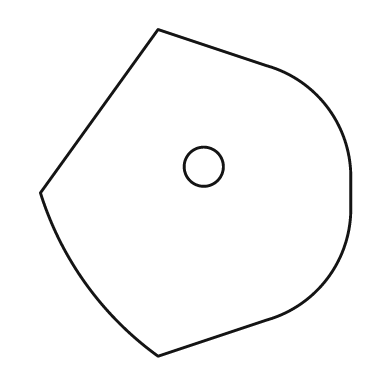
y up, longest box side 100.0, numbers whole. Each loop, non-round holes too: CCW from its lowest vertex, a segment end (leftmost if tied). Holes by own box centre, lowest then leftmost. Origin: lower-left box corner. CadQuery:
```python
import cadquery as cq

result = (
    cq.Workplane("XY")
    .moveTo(36.0, 0.0)
    .lineTo(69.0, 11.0)
    .threePointArc((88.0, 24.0), (95.0, 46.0))
    .lineTo(95.0, 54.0)
    .threePointArc((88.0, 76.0), (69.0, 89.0))
    .lineTo(36.0, 100.0)
    .lineTo(0.0, 50.0)
    .threePointArc((14.0, 22.0), (36.0, 0.0))
    .close()
    .moveTo(50.0, 58.0)
    .circle(6.0)
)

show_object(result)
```